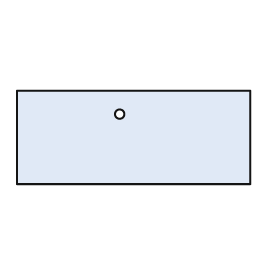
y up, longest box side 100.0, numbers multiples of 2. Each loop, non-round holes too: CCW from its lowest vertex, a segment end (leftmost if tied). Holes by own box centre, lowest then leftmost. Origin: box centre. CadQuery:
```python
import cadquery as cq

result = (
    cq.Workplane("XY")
    .moveTo(-50.0, -20.0)
    .lineTo(50.0, -20.0)
    .lineTo(50.0, 20.0)
    .lineTo(-50.0, 20.0)
    .close()
    .moveTo(-6.0, 10.0)
    .circle(2.0)
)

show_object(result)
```